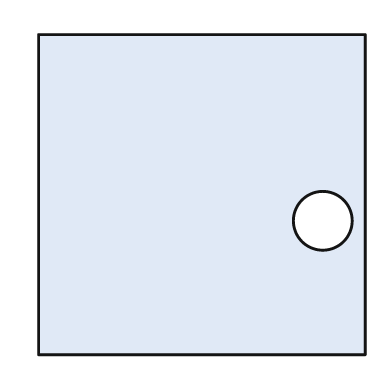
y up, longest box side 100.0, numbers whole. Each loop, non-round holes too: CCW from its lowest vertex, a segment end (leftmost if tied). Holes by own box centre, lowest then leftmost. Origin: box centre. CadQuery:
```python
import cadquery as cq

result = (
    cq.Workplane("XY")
    .moveTo(-50.0, -49.0)
    .lineTo(50.0, -49.0)
    .lineTo(50.0, 49.0)
    .lineTo(-50.0, 49.0)
    .close()
    .moveTo(37.0, -8.0)
    .circle(9.0)
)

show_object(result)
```